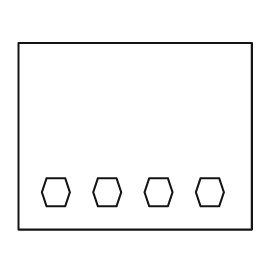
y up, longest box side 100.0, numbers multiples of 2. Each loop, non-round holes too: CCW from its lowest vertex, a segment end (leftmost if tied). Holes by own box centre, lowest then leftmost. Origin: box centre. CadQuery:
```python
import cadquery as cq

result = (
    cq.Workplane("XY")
    .moveTo(-50.0, -40.0)
    .lineTo(50.0, -40.0)
    .lineTo(50.0, 40.0)
    .lineTo(-50.0, 40.0)
    .close()
    .moveTo(-38.0, -30.0)
    .lineTo(-30.0, -30.0)
    .lineTo(-28.0, -24.0)
    .lineTo(-30.0, -18.0)
    .lineTo(-38.0, -18.0)
    .lineTo(-40.0, -24.0)
    .close()
    .moveTo(-16.0, -30.0)
    .lineTo(-8.0, -30.0)
    .lineTo(-6.0, -24.0)
    .lineTo(-8.0, -18.0)
    .lineTo(-16.0, -18.0)
    .lineTo(-18.0, -24.0)
    .close()
    .moveTo(6.0, -30.0)
    .lineTo(14.0, -30.0)
    .lineTo(16.0, -24.0)
    .lineTo(14.0, -18.0)
    .lineTo(6.0, -18.0)
    .lineTo(4.0, -24.0)
    .close()
    .moveTo(28.0, -30.0)
    .lineTo(36.0, -30.0)
    .lineTo(38.0, -24.0)
    .lineTo(36.0, -18.0)
    .lineTo(28.0, -18.0)
    .lineTo(26.0, -24.0)
    .close()
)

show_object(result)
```